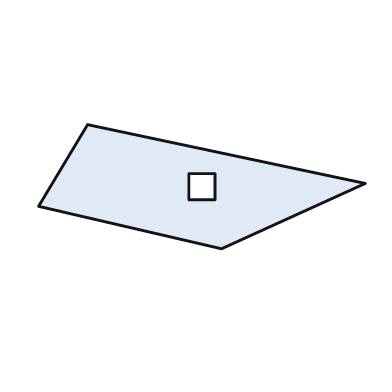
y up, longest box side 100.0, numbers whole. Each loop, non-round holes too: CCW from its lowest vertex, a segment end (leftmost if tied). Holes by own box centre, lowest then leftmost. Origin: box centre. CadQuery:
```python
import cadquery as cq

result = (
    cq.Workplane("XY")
    .moveTo(6.0, -19.0)
    .lineTo(50.0, 1.0)
    .lineTo(-35.0, 19.0)
    .lineTo(-50.0, -6.0)
    .close()
    .moveTo(-4.0, -4.0)
    .lineTo(4.0, -4.0)
    .lineTo(4.0, 4.0)
    .lineTo(-4.0, 4.0)
    .close()
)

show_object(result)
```